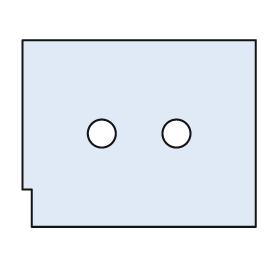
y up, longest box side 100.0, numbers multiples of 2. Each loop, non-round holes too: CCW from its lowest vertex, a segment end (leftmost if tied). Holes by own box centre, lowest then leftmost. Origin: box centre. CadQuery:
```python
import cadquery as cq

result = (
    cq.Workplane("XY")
    .moveTo(-46.0, -40.0)
    .lineTo(50.0, -40.0)
    .lineTo(50.0, 40.0)
    .lineTo(-50.0, 40.0)
    .lineTo(-50.0, -24.0)
    .lineTo(-46.0, -24.0)
    .close()
    .moveTo(-16.0, 0.0)
    .circle(6.0)
    .moveTo(16.0, 0.0)
    .circle(6.0)
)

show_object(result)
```